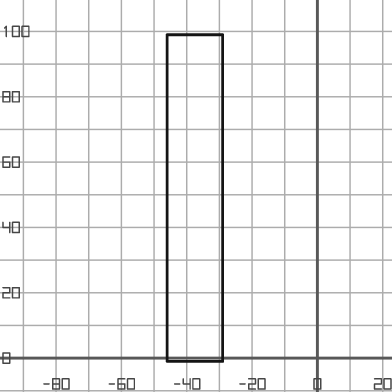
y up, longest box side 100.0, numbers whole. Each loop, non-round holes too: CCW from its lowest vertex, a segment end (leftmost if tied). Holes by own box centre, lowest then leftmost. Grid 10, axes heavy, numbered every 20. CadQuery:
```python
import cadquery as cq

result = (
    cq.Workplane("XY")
    .moveTo(-46.0, -1.0)
    .lineTo(-29.0, -1.0)
    .lineTo(-29.0, 99.0)
    .lineTo(-46.0, 99.0)
    .close()
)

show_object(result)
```